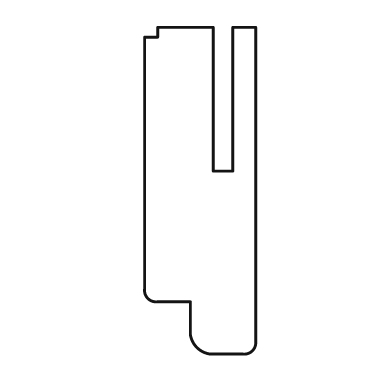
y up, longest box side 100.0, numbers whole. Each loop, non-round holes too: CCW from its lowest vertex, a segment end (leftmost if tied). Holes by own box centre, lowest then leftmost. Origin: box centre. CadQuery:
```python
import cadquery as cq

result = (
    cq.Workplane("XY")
    .moveTo(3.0, -50.0)
    .lineTo(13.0, -50.0)
    .threePointArc((16.0, -49.0), (17.0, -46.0))
    .lineTo(17.0, 50.0)
    .lineTo(10.0, 50.0)
    .lineTo(10.0, 6.0)
    .lineTo(4.0, 6.0)
    .lineTo(4.0, 50.0)
    .lineTo(-13.0, 50.0)
    .lineTo(-13.0, 47.0)
    .lineTo(-17.0, 47.0)
    .lineTo(-17.0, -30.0)
    .threePointArc((-16.0, -33.0), (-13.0, -34.0))
    .lineTo(-3.0, -34.0)
    .lineTo(-3.0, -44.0)
    .threePointArc((-1.0, -48.0), (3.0, -50.0))
    .close()
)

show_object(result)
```